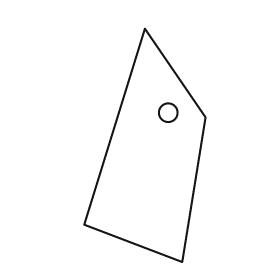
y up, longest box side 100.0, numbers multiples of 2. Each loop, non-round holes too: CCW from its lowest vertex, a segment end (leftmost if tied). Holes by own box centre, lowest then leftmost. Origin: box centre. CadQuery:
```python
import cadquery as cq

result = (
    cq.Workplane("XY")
    .moveTo(16.0, -50.0)
    .lineTo(26.0, 12.0)
    .lineTo(0.0, 50.0)
    .lineTo(-26.0, -34.0)
    .close()
    .moveTo(10.0, 14.0)
    .circle(4.0)
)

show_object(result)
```